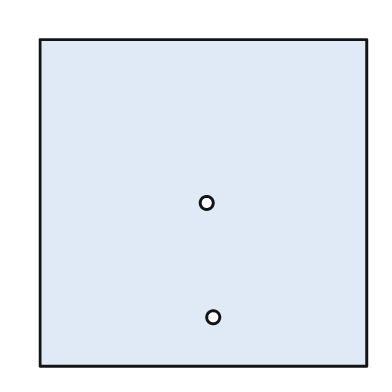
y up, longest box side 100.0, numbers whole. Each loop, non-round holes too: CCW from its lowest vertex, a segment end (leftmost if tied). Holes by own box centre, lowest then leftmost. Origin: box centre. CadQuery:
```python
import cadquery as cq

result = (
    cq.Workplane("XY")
    .moveTo(-50.0, -50.0)
    .lineTo(50.0, -50.0)
    .lineTo(50.0, 50.0)
    .lineTo(-50.0, 50.0)
    .close()
    .moveTo(3.0, -35.0)
    .circle(2.0)
    .moveTo(1.0, 0.0)
    .circle(2.0)
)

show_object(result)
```